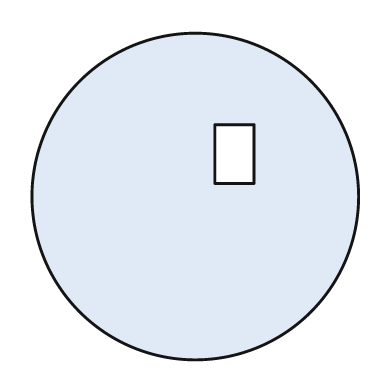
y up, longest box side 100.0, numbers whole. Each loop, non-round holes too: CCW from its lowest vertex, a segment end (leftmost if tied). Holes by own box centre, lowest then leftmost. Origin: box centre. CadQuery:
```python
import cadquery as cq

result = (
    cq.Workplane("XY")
    .moveTo(0.0, 0.0)
    .circle(50.0)
    .moveTo(6.0, 4.0)
    .lineTo(18.0, 4.0)
    .lineTo(18.0, 22.0)
    .lineTo(6.0, 22.0)
    .close()
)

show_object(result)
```